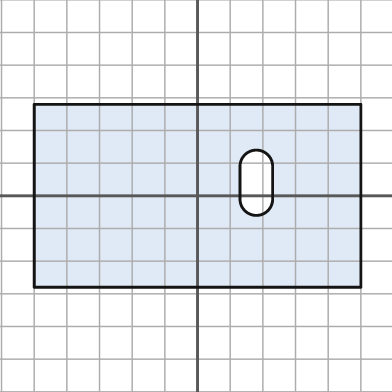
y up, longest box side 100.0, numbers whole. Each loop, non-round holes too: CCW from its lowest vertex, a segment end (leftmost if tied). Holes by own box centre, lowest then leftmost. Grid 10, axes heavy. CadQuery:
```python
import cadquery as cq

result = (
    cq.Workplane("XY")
    .moveTo(-50.0, -28.0)
    .lineTo(50.0, -28.0)
    .lineTo(50.0, 28.0)
    .lineTo(-50.0, 28.0)
    .close()
    .moveTo(13.0, -1.0)
    .threePointArc((18.0, -6.0), (23.0, -1.0))
    .lineTo(23.0, 9.0)
    .threePointArc((18.0, 14.0), (13.0, 9.0))
    .close()
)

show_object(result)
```